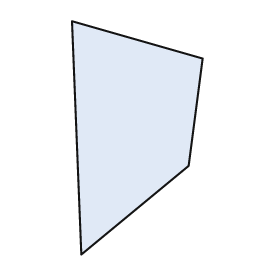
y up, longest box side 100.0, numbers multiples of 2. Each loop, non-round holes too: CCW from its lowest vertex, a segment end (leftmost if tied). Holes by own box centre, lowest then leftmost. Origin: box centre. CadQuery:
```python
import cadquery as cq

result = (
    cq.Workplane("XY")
    .moveTo(-24.0, -50.0)
    .lineTo(22.0, -12.0)
    .lineTo(28.0, 34.0)
    .lineTo(-28.0, 50.0)
    .close()
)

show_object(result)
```